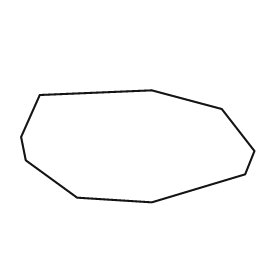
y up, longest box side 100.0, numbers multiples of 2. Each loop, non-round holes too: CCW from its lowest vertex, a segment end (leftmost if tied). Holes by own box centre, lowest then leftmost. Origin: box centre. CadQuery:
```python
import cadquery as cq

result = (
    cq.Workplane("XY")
    .moveTo(6.0, -24.0)
    .lineTo(46.0, -12.0)
    .lineTo(50.0, -2.0)
    .lineTo(36.0, 16.0)
    .lineTo(6.0, 24.0)
    .lineTo(-42.0, 22.0)
    .lineTo(-50.0, 4.0)
    .lineTo(-48.0, -6.0)
    .lineTo(-26.0, -22.0)
    .close()
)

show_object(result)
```